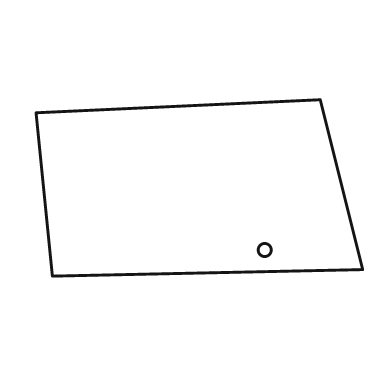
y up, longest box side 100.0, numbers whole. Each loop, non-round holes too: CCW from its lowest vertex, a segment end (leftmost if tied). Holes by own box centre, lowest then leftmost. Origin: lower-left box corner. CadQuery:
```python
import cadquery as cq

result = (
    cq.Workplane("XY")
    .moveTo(5.0, 0.0)
    .lineTo(100.0, 2.0)
    .lineTo(87.0, 54.0)
    .lineTo(0.0, 50.0)
    .close()
    .moveTo(70.0, 8.0)
    .circle(2.0)
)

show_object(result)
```